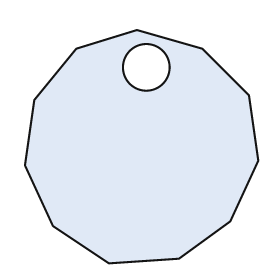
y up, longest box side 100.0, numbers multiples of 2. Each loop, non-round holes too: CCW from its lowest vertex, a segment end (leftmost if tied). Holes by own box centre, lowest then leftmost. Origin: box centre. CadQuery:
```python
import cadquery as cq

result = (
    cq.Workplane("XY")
    .moveTo(-14.0, -50.0)
    .lineTo(16.0, -48.0)
    .lineTo(38.0, -32.0)
    .lineTo(50.0, -6.0)
    .lineTo(46.0, 22.0)
    .lineTo(26.0, 42.0)
    .lineTo(-2.0, 50.0)
    .lineTo(-28.0, 42.0)
    .lineTo(-46.0, 20.0)
    .lineTo(-50.0, -8.0)
    .lineTo(-38.0, -34.0)
    .close()
    .moveTo(2.0, 34.0)
    .circle(10.0)
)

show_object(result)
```